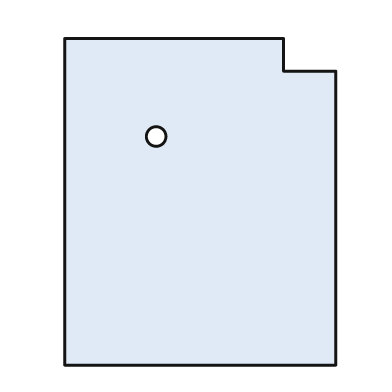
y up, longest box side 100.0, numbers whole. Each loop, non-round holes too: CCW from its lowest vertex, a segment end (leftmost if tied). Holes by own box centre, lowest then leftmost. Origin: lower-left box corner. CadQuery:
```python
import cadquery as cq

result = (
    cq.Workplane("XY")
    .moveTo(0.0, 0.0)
    .lineTo(83.0, 0.0)
    .lineTo(83.0, 90.0)
    .lineTo(67.0, 90.0)
    .lineTo(67.0, 100.0)
    .lineTo(0.0, 100.0)
    .close()
    .moveTo(28.0, 70.0)
    .circle(3.0)
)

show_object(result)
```